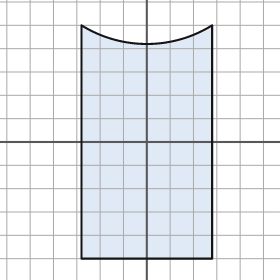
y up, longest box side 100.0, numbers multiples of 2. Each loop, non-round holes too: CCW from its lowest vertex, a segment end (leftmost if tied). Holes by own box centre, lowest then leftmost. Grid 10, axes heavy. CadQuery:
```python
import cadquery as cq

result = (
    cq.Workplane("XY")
    .moveTo(-28.0, -50.0)
    .lineTo(28.0, -50.0)
    .lineTo(28.0, 50.0)
    .threePointArc((0.0, 42.0), (-28.0, 50.0))
    .close()
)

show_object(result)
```